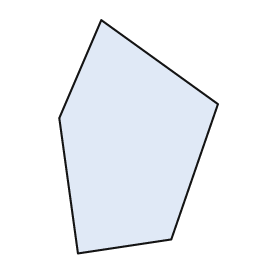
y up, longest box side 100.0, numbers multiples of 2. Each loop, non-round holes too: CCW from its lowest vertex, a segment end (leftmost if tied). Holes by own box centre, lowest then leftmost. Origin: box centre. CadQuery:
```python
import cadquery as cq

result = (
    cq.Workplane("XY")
    .moveTo(-26.0, -50.0)
    .lineTo(14.0, -44.0)
    .lineTo(34.0, 14.0)
    .lineTo(-16.0, 50.0)
    .lineTo(-34.0, 8.0)
    .close()
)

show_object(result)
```